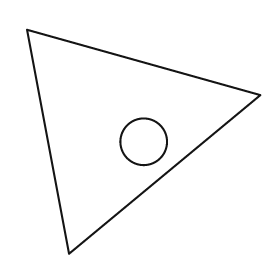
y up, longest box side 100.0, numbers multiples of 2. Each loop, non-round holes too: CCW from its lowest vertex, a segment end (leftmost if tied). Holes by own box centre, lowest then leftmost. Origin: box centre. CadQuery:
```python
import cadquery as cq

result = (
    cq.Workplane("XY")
    .moveTo(-32.0, -48.0)
    .lineTo(50.0, 20.0)
    .lineTo(-50.0, 48.0)
    .close()
    .moveTo(0.0, 0.0)
    .circle(10.0)
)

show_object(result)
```